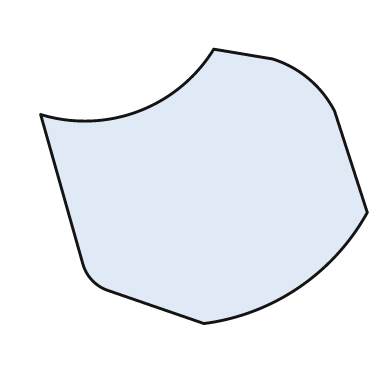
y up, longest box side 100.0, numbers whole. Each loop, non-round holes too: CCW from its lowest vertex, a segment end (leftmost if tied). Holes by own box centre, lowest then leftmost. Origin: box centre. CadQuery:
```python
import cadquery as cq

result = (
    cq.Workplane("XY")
    .moveTo(0.0, -42.0)
    .threePointArc((29.0, -31.0), (50.0, -8.0))
    .lineTo(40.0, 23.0)
    .threePointArc((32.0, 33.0), (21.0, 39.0))
    .lineTo(3.0, 42.0)
    .threePointArc((-20.0, 23.0), (-50.0, 22.0))
    .lineTo(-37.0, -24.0)
    .threePointArc((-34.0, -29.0), (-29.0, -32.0))
    .close()
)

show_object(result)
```